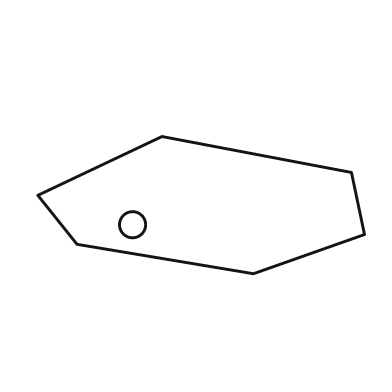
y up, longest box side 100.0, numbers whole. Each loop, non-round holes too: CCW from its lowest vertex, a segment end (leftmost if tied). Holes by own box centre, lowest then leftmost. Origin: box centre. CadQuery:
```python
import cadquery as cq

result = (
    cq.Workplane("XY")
    .moveTo(16.0, -21.0)
    .lineTo(50.0, -9.0)
    .lineTo(46.0, 10.0)
    .lineTo(-12.0, 21.0)
    .lineTo(-50.0, 3.0)
    .lineTo(-38.0, -12.0)
    .close()
    .moveTo(-21.0, -6.0)
    .circle(4.0)
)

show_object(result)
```